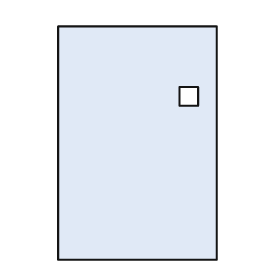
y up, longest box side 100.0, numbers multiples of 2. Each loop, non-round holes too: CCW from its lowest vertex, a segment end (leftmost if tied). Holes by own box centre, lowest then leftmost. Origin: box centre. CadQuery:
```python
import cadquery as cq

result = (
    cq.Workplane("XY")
    .moveTo(-34.0, -50.0)
    .lineTo(34.0, -50.0)
    .lineTo(34.0, 50.0)
    .lineTo(-34.0, 50.0)
    .close()
    .moveTo(18.0, 16.0)
    .lineTo(26.0, 16.0)
    .lineTo(26.0, 24.0)
    .lineTo(18.0, 24.0)
    .close()
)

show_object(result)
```